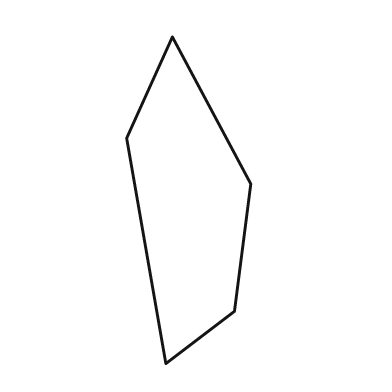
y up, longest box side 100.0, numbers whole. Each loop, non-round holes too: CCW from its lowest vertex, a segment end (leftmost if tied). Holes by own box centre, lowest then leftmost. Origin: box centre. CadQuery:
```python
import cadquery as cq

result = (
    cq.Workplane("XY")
    .moveTo(-7.0, -50.0)
    .lineTo(14.0, -34.0)
    .lineTo(19.0, 5.0)
    .lineTo(-5.0, 50.0)
    .lineTo(-19.0, 19.0)
    .close()
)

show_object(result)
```